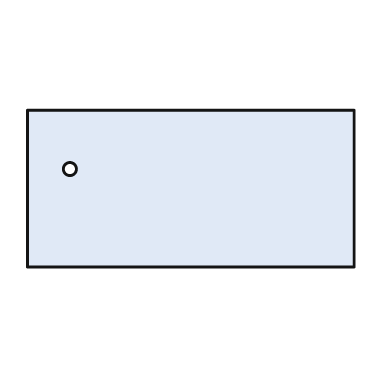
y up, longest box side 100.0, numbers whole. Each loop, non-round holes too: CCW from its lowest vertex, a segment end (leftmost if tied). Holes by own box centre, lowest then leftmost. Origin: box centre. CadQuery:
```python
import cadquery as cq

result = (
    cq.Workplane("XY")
    .moveTo(-50.0, -24.0)
    .lineTo(50.0, -24.0)
    .lineTo(50.0, 24.0)
    .lineTo(-50.0, 24.0)
    .close()
    .moveTo(-37.0, 6.0)
    .circle(2.0)
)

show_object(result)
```